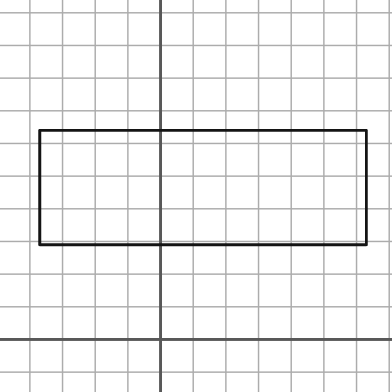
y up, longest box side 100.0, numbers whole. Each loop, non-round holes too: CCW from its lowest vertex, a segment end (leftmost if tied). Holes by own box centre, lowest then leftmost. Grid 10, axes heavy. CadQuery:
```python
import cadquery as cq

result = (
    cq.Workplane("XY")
    .moveTo(-37.0, 29.0)
    .lineTo(63.0, 29.0)
    .lineTo(63.0, 64.0)
    .lineTo(-37.0, 64.0)
    .close()
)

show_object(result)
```